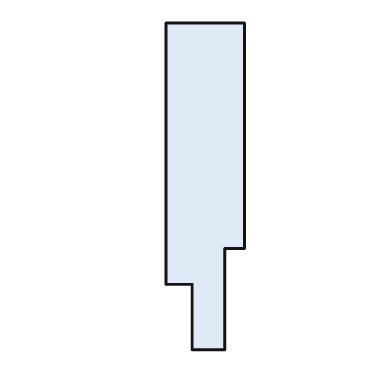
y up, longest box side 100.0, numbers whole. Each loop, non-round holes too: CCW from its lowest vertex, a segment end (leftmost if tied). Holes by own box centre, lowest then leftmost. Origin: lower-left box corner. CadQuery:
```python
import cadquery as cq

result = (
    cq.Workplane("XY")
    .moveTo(8.0, 0.0)
    .lineTo(18.0, 0.0)
    .lineTo(18.0, 31.0)
    .lineTo(24.0, 31.0)
    .lineTo(24.0, 100.0)
    .lineTo(0.0, 100.0)
    .lineTo(0.0, 20.0)
    .lineTo(8.0, 20.0)
    .close()
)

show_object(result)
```